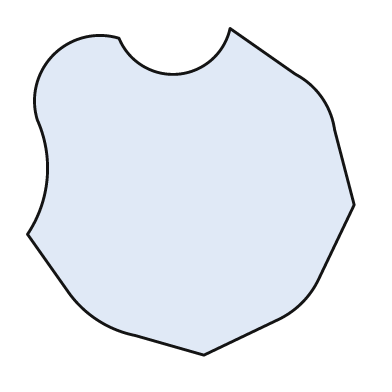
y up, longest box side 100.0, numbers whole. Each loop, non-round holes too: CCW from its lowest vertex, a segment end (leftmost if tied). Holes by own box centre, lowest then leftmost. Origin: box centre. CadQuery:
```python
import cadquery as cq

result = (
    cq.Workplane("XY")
    .moveTo(4.0, -50.0)
    .lineTo(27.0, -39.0)
    .threePointArc((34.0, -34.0), (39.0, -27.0))
    .lineTo(50.0, -4.0)
    .lineTo(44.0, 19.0)
    .threePointArc((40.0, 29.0), (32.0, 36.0))
    .lineTo(12.0, 50.0)
    .threePointArc((-4.0, 36.0), (-22.0, 47.0))
    .threePointArc((-42.0, 42.0), (-47.0, 22.0))
    .threePointArc((-44.0, 4.0), (-50.0, -13.0))
    .lineTo(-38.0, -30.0)
    .threePointArc((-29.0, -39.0), (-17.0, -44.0))
    .close()
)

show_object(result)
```